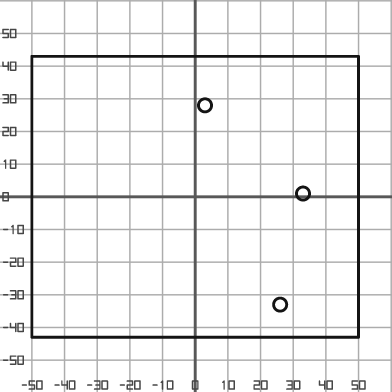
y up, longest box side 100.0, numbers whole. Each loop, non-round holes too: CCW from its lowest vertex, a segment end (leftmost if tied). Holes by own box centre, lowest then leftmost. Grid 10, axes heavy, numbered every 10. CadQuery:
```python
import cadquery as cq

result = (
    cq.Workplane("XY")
    .moveTo(-50.0, -43.0)
    .lineTo(50.0, -43.0)
    .lineTo(50.0, 43.0)
    .lineTo(-50.0, 43.0)
    .close()
    .moveTo(26.0, -33.0)
    .circle(2.0)
    .moveTo(33.0, 1.0)
    .circle(2.0)
    .moveTo(3.0, 28.0)
    .circle(2.0)
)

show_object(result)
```